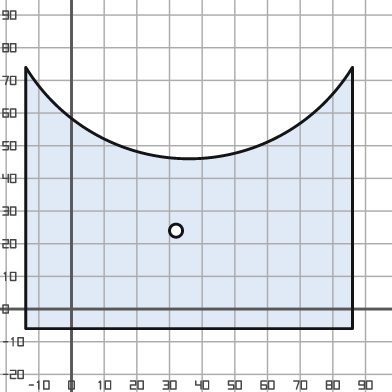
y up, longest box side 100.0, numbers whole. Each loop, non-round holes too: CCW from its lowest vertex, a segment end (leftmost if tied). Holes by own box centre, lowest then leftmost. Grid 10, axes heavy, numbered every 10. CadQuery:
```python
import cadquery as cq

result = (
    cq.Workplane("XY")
    .moveTo(-14.0, -6.0)
    .lineTo(86.0, -6.0)
    .lineTo(86.0, 74.0)
    .threePointArc((36.0, 46.0), (-14.0, 74.0))
    .close()
    .moveTo(32.0, 24.0)
    .circle(2.0)
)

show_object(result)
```